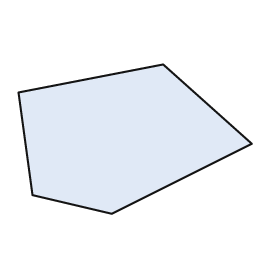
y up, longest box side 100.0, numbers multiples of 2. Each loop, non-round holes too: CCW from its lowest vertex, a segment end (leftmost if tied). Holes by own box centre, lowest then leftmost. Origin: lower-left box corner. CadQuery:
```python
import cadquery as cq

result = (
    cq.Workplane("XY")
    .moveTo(40.0, 0.0)
    .lineTo(100.0, 30.0)
    .lineTo(62.0, 64.0)
    .lineTo(0.0, 52.0)
    .lineTo(6.0, 8.0)
    .close()
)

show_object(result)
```